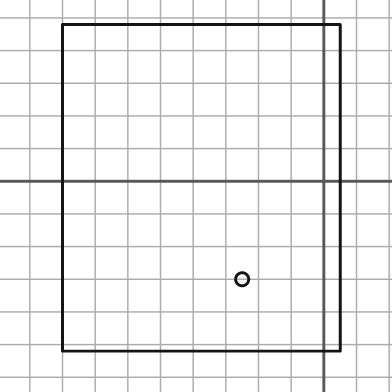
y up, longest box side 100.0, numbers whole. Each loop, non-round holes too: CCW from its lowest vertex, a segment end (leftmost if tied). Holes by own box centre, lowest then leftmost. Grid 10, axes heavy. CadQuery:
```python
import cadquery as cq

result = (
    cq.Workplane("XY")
    .moveTo(-80.0, -52.0)
    .lineTo(5.0, -52.0)
    .lineTo(5.0, 48.0)
    .lineTo(-80.0, 48.0)
    .close()
    .moveTo(-25.0, -30.0)
    .circle(2.0)
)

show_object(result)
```